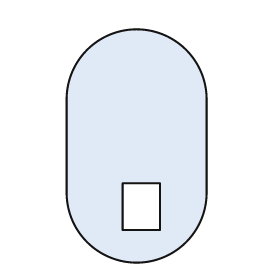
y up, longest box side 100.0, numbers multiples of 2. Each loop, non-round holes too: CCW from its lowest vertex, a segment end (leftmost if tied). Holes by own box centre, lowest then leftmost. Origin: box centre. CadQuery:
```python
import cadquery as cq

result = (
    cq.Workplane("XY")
    .moveTo(-30.0, -20.0)
    .threePointArc((0.0, -50.0), (30.0, -20.0))
    .lineTo(30.0, 20.0)
    .threePointArc((0.0, 50.0), (-30.0, 20.0))
    .close()
    .moveTo(-6.0, -36.0)
    .lineTo(10.0, -36.0)
    .lineTo(10.0, -16.0)
    .lineTo(-6.0, -16.0)
    .close()
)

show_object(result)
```